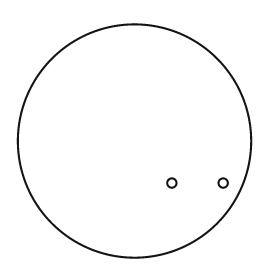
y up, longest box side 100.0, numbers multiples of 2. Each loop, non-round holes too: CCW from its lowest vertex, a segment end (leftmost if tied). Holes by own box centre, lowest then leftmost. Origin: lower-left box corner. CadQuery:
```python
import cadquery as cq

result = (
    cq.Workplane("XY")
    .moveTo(50.0, 50.0)
    .circle(50.0)
    .moveTo(66.0, 32.0)
    .circle(2.0)
    .moveTo(88.0, 32.0)
    .circle(2.0)
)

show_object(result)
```